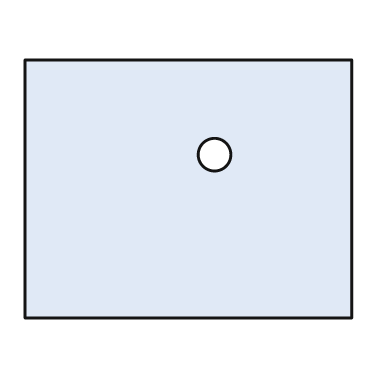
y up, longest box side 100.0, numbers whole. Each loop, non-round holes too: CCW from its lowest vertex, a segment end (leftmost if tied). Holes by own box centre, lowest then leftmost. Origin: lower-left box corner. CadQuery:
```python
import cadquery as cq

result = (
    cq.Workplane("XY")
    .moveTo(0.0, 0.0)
    .lineTo(100.0, 0.0)
    .lineTo(100.0, 79.0)
    .lineTo(0.0, 79.0)
    .close()
    .moveTo(58.0, 50.0)
    .circle(5.0)
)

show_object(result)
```